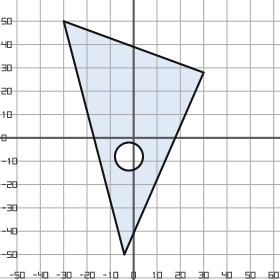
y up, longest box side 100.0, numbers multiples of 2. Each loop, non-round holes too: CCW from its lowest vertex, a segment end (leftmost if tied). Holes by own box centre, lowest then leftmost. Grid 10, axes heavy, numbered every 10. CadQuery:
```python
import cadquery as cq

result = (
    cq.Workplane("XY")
    .moveTo(-4.0, -50.0)
    .lineTo(30.0, 28.0)
    .lineTo(-30.0, 50.0)
    .close()
    .moveTo(-2.0, -8.0)
    .circle(6.0)
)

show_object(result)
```